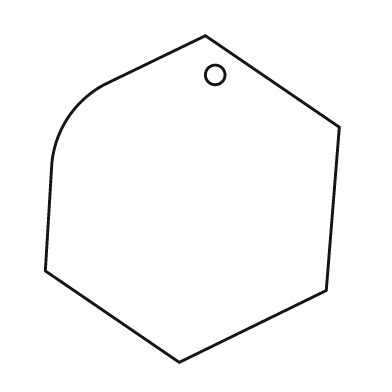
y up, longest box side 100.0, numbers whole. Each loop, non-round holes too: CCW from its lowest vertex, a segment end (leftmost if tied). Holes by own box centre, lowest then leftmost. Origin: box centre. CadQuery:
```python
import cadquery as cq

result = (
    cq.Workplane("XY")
    .moveTo(-4.0, -50.0)
    .lineTo(41.0, -28.0)
    .lineTo(45.0, 22.0)
    .lineTo(4.0, 50.0)
    .lineTo(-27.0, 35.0)
    .threePointArc((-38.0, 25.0), (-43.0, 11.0))
    .lineTo(-45.0, -22.0)
    .close()
    .moveTo(7.0, 38.0)
    .circle(3.0)
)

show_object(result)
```